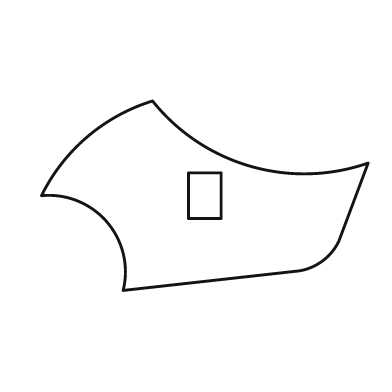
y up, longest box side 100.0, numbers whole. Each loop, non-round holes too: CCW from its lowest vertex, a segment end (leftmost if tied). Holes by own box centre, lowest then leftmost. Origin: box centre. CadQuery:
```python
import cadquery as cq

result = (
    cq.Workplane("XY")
    .moveTo(-25.0, -29.0)
    .lineTo(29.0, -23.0)
    .threePointArc((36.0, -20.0), (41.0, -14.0))
    .lineTo(50.0, 10.0)
    .threePointArc((14.0, 9.0), (-16.0, 29.0))
    .threePointArc((-36.0, 18.0), (-50.0, 0.0))
    .threePointArc((-30.0, -8.0), (-25.0, -29.0))
    .close()
    .moveTo(-5.0, -7.0)
    .lineTo(5.0, -7.0)
    .lineTo(5.0, 7.0)
    .lineTo(-5.0, 7.0)
    .close()
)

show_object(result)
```